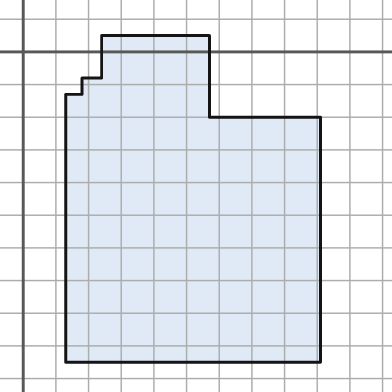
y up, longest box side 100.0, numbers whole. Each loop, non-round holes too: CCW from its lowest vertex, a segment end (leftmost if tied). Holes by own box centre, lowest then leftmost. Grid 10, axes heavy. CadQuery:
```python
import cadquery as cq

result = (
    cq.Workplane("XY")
    .moveTo(13.0, -95.0)
    .lineTo(91.0, -95.0)
    .lineTo(91.0, -20.0)
    .lineTo(57.0, -20.0)
    .lineTo(57.0, 5.0)
    .lineTo(24.0, 5.0)
    .lineTo(24.0, -8.0)
    .lineTo(18.0, -8.0)
    .lineTo(18.0, -13.0)
    .lineTo(13.0, -13.0)
    .close()
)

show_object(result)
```